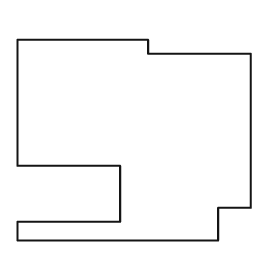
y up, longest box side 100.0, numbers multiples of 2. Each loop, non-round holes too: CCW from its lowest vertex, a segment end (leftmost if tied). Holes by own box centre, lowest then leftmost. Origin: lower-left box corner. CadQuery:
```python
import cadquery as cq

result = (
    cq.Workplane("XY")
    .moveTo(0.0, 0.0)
    .lineTo(86.0, 0.0)
    .lineTo(86.0, 14.0)
    .lineTo(100.0, 14.0)
    .lineTo(100.0, 80.0)
    .lineTo(56.0, 80.0)
    .lineTo(56.0, 86.0)
    .lineTo(0.0, 86.0)
    .lineTo(0.0, 32.0)
    .lineTo(44.0, 32.0)
    .lineTo(44.0, 8.0)
    .lineTo(0.0, 8.0)
    .close()
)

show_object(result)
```